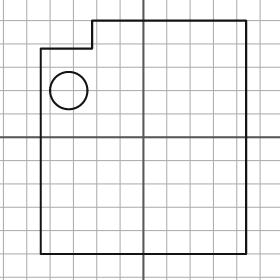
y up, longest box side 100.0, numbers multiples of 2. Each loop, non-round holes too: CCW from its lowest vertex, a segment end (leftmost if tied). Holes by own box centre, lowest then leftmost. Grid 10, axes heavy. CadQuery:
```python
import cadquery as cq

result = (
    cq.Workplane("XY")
    .moveTo(-44.0, -50.0)
    .lineTo(44.0, -50.0)
    .lineTo(44.0, 50.0)
    .lineTo(-22.0, 50.0)
    .lineTo(-22.0, 38.0)
    .lineTo(-44.0, 38.0)
    .close()
    .moveTo(-32.0, 20.0)
    .circle(8.0)
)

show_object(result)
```